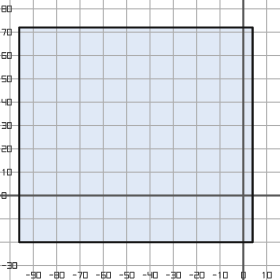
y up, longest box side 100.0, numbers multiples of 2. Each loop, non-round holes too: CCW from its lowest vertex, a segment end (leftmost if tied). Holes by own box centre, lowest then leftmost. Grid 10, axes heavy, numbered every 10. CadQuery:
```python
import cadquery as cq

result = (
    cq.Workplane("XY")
    .moveTo(-96.0, -20.0)
    .lineTo(4.0, -20.0)
    .lineTo(4.0, 72.0)
    .lineTo(-96.0, 72.0)
    .close()
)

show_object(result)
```